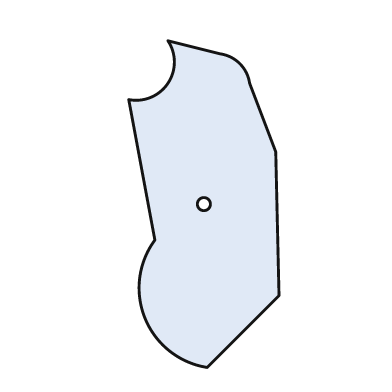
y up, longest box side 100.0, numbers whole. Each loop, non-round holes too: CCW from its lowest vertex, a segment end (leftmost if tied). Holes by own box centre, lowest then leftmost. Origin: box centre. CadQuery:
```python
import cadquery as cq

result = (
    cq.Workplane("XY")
    .moveTo(1.0, -50.0)
    .lineTo(23.0, -28.0)
    .lineTo(22.0, 16.0)
    .lineTo(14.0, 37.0)
    .threePointArc((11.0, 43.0), (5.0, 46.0))
    .lineTo(-11.0, 50.0)
    .threePointArc((-11.0, 37.0), (-23.0, 32.0))
    .lineTo(-15.0, -11.0)
    .threePointArc((-18.0, -35.0), (1.0, -50.0))
    .close()
    .moveTo(0.0, 0.0)
    .circle(2.0)
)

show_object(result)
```